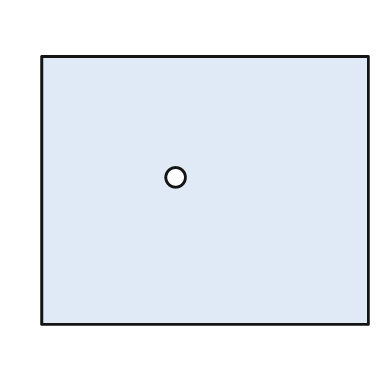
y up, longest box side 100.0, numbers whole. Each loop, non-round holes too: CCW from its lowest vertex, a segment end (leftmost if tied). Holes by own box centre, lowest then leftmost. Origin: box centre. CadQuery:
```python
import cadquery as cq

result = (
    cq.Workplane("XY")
    .moveTo(-50.0, -41.0)
    .lineTo(50.0, -41.0)
    .lineTo(50.0, 41.0)
    .lineTo(-50.0, 41.0)
    .close()
    .moveTo(-9.0, 4.0)
    .circle(3.0)
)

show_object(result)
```